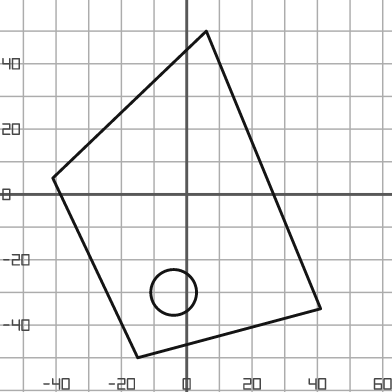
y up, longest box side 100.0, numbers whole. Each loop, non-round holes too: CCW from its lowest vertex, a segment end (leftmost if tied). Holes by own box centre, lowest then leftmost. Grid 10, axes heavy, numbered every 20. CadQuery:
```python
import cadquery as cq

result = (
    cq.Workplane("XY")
    .moveTo(-15.0, -50.0)
    .lineTo(41.0, -35.0)
    .lineTo(6.0, 50.0)
    .lineTo(-41.0, 5.0)
    .close()
    .moveTo(-4.0, -30.0)
    .circle(7.0)
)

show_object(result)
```